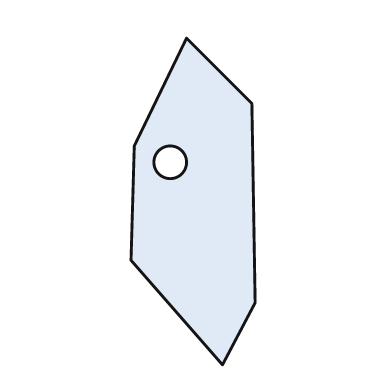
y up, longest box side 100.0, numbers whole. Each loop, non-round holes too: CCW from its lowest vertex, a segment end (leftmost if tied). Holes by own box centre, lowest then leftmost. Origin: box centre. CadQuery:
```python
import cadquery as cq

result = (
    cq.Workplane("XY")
    .moveTo(9.0, -50.0)
    .lineTo(19.0, -31.0)
    .lineTo(18.0, 30.0)
    .lineTo(-2.0, 50.0)
    .lineTo(-18.0, 17.0)
    .lineTo(-19.0, -18.0)
    .close()
    .moveTo(-7.0, 12.0)
    .circle(5.0)
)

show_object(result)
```